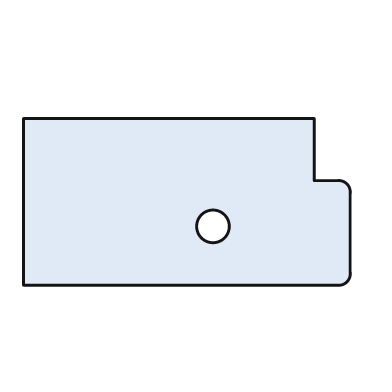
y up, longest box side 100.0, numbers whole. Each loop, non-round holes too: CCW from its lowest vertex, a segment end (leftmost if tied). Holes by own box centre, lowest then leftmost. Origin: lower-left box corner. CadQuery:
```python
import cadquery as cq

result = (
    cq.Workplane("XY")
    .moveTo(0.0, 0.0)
    .lineTo(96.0, 0.0)
    .threePointArc((99.0, 1.0), (100.0, 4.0))
    .lineTo(100.0, 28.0)
    .threePointArc((99.0, 31.0), (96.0, 32.0))
    .lineTo(89.0, 32.0)
    .lineTo(89.0, 51.0)
    .lineTo(0.0, 51.0)
    .close()
    .moveTo(58.0, 18.0)
    .circle(5.0)
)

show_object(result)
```